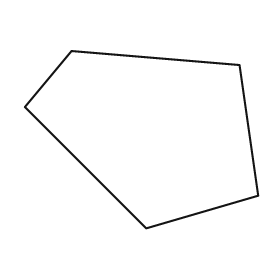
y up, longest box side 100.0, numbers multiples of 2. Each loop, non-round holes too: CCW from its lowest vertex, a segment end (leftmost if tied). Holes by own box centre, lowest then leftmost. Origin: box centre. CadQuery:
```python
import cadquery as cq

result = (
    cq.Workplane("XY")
    .moveTo(2.0, -38.0)
    .lineTo(50.0, -24.0)
    .lineTo(42.0, 32.0)
    .lineTo(-30.0, 38.0)
    .lineTo(-50.0, 14.0)
    .close()
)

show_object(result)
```